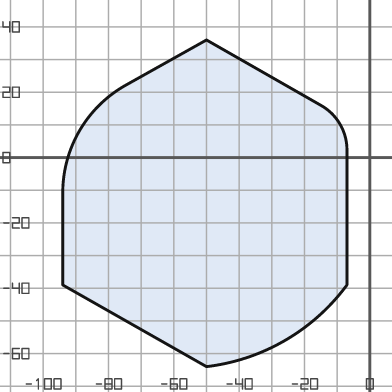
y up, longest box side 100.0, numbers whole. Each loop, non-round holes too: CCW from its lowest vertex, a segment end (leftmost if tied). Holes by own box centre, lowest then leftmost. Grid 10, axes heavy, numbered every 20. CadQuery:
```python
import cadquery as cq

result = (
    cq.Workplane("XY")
    .moveTo(-50.0, -64.0)
    .threePointArc((-26.0, -56.0), (-7.0, -39.0))
    .lineTo(-7.0, 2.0)
    .threePointArc((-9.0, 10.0), (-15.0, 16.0))
    .lineTo(-50.0, 36.0)
    .lineTo(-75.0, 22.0)
    .threePointArc((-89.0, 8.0), (-94.0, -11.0))
    .lineTo(-94.0, -39.0)
    .close()
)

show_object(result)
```